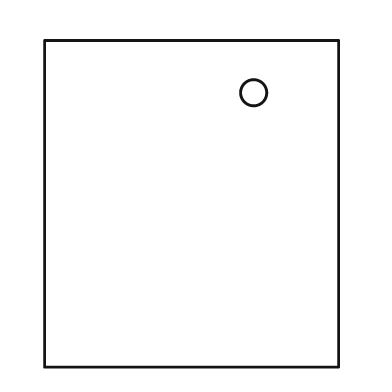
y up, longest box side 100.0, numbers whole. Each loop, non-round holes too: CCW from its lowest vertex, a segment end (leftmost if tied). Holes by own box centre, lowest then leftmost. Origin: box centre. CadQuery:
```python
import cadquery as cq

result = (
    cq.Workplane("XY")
    .moveTo(-45.0, -50.0)
    .lineTo(45.0, -50.0)
    .lineTo(45.0, 50.0)
    .lineTo(-45.0, 50.0)
    .close()
    .moveTo(19.0, 34.0)
    .circle(4.0)
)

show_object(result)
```